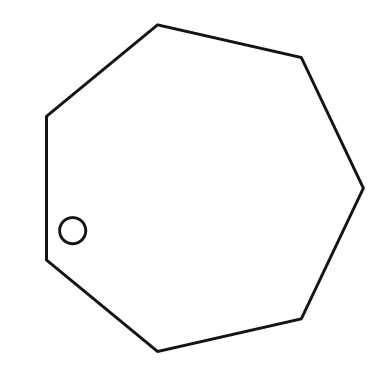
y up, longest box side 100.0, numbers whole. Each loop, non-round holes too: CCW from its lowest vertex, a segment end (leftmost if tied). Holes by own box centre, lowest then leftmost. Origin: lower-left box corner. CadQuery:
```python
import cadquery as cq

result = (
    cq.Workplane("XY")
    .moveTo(34.0, 0.0)
    .lineTo(78.0, 10.0)
    .lineTo(97.0, 50.0)
    .lineTo(78.0, 90.0)
    .lineTo(34.0, 100.0)
    .lineTo(0.0, 72.0)
    .lineTo(0.0, 28.0)
    .close()
    .moveTo(8.0, 37.0)
    .circle(4.0)
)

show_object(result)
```